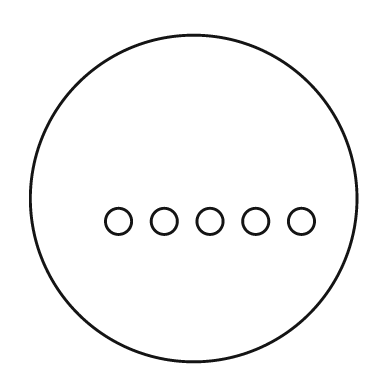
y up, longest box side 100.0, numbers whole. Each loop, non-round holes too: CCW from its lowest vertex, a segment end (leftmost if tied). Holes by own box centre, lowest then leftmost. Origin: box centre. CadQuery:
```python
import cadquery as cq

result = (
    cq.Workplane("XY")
    .moveTo(0.0, 0.0)
    .circle(50.0)
    .moveTo(-23.0, -7.0)
    .circle(4.0)
    .moveTo(-9.0, -7.0)
    .circle(4.0)
    .moveTo(5.0, -7.0)
    .circle(4.0)
    .moveTo(19.0, -7.0)
    .circle(4.0)
    .moveTo(33.0, -7.0)
    .circle(4.0)
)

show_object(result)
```